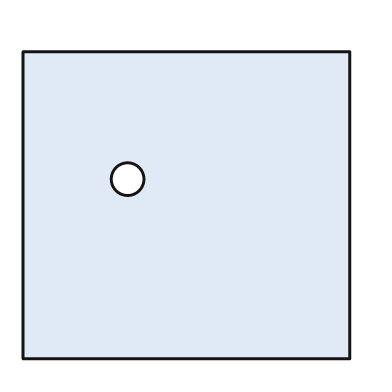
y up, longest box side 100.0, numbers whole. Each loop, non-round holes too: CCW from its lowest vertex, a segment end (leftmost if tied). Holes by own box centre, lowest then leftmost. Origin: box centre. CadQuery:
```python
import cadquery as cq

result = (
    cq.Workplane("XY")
    .moveTo(-50.0, -47.0)
    .lineTo(50.0, -47.0)
    .lineTo(50.0, 47.0)
    .lineTo(-50.0, 47.0)
    .close()
    .moveTo(-18.0, 8.0)
    .circle(5.0)
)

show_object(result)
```